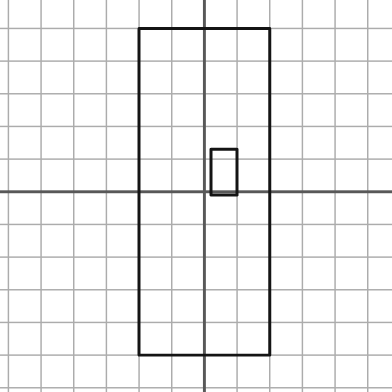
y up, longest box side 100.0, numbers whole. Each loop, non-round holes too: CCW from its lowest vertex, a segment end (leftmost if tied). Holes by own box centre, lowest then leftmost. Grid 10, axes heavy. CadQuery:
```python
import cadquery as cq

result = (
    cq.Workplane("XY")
    .moveTo(-20.0, -50.0)
    .lineTo(20.0, -50.0)
    .lineTo(20.0, 50.0)
    .lineTo(-20.0, 50.0)
    .close()
    .moveTo(2.0, -1.0)
    .lineTo(10.0, -1.0)
    .lineTo(10.0, 13.0)
    .lineTo(2.0, 13.0)
    .close()
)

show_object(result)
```